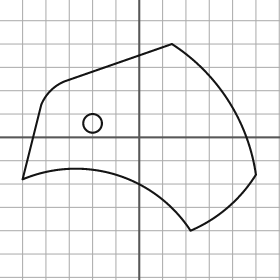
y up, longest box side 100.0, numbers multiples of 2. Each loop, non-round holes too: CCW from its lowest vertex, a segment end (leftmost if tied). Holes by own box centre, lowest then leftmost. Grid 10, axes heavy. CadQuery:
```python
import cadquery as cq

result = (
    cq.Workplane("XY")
    .moveTo(22.0, -40.0)
    .threePointArc((38.0, -30.0), (50.0, -16.0))
    .threePointArc((38.0, 16.0), (14.0, 40.0))
    .lineTo(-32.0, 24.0)
    .threePointArc((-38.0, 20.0), (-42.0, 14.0))
    .lineTo(-50.0, -18.0)
    .threePointArc((-10.0, -16.0), (22.0, -40.0))
    .close()
    .moveTo(-20.0, 6.0)
    .circle(4.0)
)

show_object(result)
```